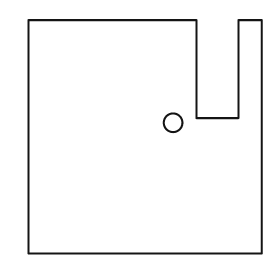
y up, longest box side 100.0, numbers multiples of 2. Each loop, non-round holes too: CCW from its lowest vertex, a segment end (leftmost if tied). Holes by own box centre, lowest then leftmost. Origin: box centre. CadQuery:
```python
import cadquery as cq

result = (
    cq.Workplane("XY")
    .moveTo(-50.0, -50.0)
    .lineTo(50.0, -50.0)
    .lineTo(50.0, 50.0)
    .lineTo(40.0, 50.0)
    .lineTo(40.0, 8.0)
    .lineTo(22.0, 8.0)
    .lineTo(22.0, 50.0)
    .lineTo(-50.0, 50.0)
    .close()
    .moveTo(12.0, 6.0)
    .circle(4.0)
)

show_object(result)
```